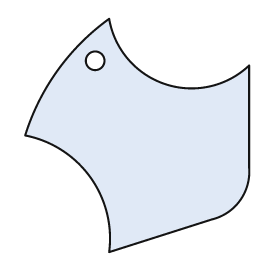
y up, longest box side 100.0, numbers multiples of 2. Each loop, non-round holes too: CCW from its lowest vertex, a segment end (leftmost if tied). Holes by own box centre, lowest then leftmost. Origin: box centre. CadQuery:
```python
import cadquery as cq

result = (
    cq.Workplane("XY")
    .moveTo(-12.0, -50.0)
    .lineTo(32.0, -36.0)
    .threePointArc((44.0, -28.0), (48.0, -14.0))
    .lineTo(48.0, 30.0)
    .threePointArc((12.0, 22.0), (-12.0, 50.0))
    .threePointArc((-34.0, 28.0), (-48.0, 0.0))
    .threePointArc((-20.0, -18.0), (-12.0, -50.0))
    .close()
    .moveTo(-18.0, 32.0)
    .circle(4.0)
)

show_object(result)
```